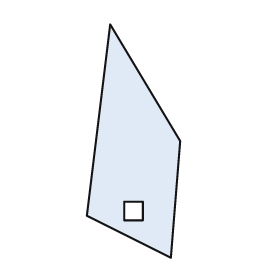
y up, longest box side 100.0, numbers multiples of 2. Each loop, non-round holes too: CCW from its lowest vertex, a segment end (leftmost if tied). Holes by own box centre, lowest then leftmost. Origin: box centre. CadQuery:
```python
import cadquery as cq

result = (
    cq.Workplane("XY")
    .moveTo(16.0, -50.0)
    .lineTo(20.0, 0.0)
    .lineTo(-10.0, 50.0)
    .lineTo(-20.0, -32.0)
    .close()
    .moveTo(-4.0, -34.0)
    .lineTo(4.0, -34.0)
    .lineTo(4.0, -26.0)
    .lineTo(-4.0, -26.0)
    .close()
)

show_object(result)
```